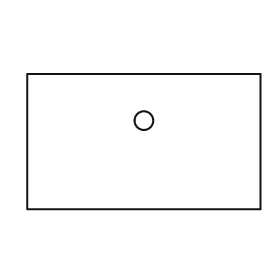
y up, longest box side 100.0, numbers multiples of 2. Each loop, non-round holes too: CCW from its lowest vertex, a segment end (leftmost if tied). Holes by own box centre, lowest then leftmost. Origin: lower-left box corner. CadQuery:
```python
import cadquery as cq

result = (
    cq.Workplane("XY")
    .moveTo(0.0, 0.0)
    .lineTo(100.0, 0.0)
    .lineTo(100.0, 58.0)
    .lineTo(0.0, 58.0)
    .close()
    .moveTo(50.0, 38.0)
    .circle(4.0)
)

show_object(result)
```